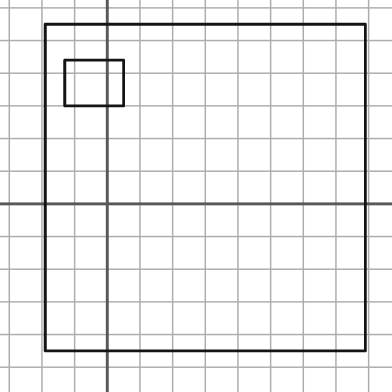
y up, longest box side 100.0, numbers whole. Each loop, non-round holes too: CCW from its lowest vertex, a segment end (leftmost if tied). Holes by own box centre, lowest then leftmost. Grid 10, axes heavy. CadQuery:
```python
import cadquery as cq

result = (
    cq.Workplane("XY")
    .moveTo(-19.0, -45.0)
    .lineTo(79.0, -45.0)
    .lineTo(79.0, 55.0)
    .lineTo(-19.0, 55.0)
    .close()
    .moveTo(-13.0, 30.0)
    .lineTo(5.0, 30.0)
    .lineTo(5.0, 44.0)
    .lineTo(-13.0, 44.0)
    .close()
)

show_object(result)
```